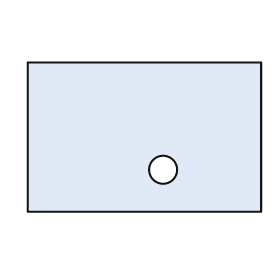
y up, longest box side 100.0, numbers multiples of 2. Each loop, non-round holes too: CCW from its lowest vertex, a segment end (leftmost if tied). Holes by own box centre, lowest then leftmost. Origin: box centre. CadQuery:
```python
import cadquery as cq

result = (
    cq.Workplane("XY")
    .moveTo(-50.0, -32.0)
    .lineTo(50.0, -32.0)
    .lineTo(50.0, 32.0)
    .lineTo(-50.0, 32.0)
    .close()
    .moveTo(8.0, -14.0)
    .circle(6.0)
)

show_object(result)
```